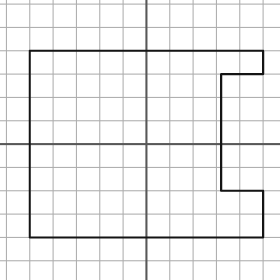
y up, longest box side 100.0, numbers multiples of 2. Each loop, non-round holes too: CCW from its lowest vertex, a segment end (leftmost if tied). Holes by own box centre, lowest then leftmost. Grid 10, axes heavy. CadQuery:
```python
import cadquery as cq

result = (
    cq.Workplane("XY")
    .moveTo(-50.0, -40.0)
    .lineTo(50.0, -40.0)
    .lineTo(50.0, -20.0)
    .lineTo(32.0, -20.0)
    .lineTo(32.0, 30.0)
    .lineTo(50.0, 30.0)
    .lineTo(50.0, 40.0)
    .lineTo(-50.0, 40.0)
    .close()
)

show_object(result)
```